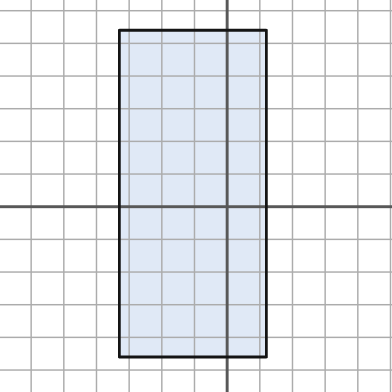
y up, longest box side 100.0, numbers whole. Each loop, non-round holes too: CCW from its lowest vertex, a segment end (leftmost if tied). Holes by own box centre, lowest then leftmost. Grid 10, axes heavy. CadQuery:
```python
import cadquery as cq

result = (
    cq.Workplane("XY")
    .moveTo(-33.0, -46.0)
    .lineTo(12.0, -46.0)
    .lineTo(12.0, 54.0)
    .lineTo(-33.0, 54.0)
    .close()
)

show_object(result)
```